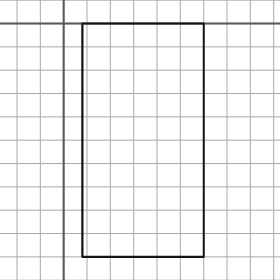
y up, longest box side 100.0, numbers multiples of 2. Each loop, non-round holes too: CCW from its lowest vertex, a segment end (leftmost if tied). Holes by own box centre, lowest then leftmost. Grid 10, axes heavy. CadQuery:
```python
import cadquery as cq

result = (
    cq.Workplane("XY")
    .moveTo(8.0, -100.0)
    .lineTo(60.0, -100.0)
    .lineTo(60.0, 0.0)
    .lineTo(8.0, 0.0)
    .close()
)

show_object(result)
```